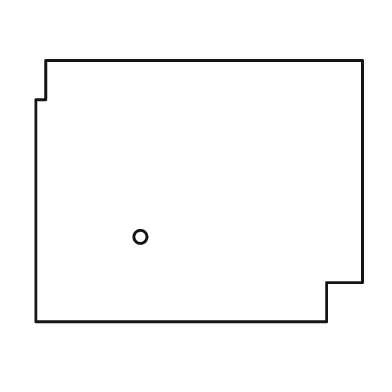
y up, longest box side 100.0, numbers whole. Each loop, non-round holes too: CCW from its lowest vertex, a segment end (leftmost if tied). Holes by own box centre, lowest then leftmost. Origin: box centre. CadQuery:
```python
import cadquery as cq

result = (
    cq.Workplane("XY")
    .moveTo(-50.0, -40.0)
    .lineTo(39.0, -40.0)
    .lineTo(39.0, -28.0)
    .lineTo(50.0, -28.0)
    .lineTo(50.0, 40.0)
    .lineTo(-47.0, 40.0)
    .lineTo(-47.0, 28.0)
    .lineTo(-50.0, 28.0)
    .close()
    .moveTo(-18.0, -14.0)
    .circle(2.0)
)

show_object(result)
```